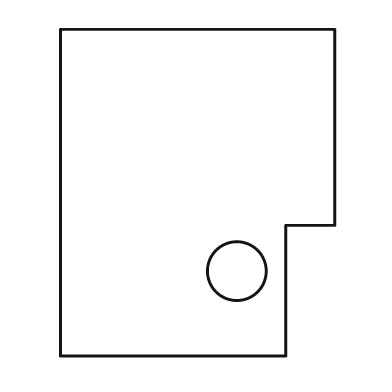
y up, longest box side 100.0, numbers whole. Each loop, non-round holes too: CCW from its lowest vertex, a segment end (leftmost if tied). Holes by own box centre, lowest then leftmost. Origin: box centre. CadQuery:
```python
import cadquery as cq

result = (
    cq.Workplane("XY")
    .moveTo(-42.0, -50.0)
    .lineTo(27.0, -50.0)
    .lineTo(27.0, -10.0)
    .lineTo(42.0, -10.0)
    .lineTo(42.0, 50.0)
    .lineTo(-42.0, 50.0)
    .close()
    .moveTo(12.0, -24.0)
    .circle(9.0)
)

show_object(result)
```